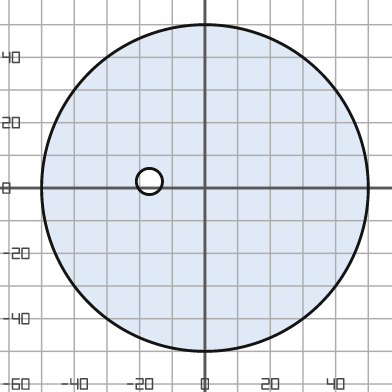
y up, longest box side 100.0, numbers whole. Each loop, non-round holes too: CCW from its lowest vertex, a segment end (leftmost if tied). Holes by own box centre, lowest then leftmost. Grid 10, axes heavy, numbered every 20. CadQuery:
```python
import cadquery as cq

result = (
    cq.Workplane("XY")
    .moveTo(0.0, 0.0)
    .circle(50.0)
    .moveTo(-17.0, 2.0)
    .circle(4.0)
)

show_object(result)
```